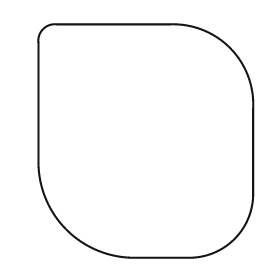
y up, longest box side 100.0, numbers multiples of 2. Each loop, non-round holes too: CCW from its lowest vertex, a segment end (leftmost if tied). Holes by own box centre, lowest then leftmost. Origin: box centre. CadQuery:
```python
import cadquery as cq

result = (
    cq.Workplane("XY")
    .moveTo(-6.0, -50.0)
    .lineTo(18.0, -50.0)
    .threePointArc((38.0, -42.0), (46.0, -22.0))
    .lineTo(46.0, 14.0)
    .threePointArc((36.0, 40.0), (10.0, 50.0))
    .lineTo(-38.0, 50.0)
    .threePointArc((-44.0, 48.0), (-46.0, 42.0))
    .lineTo(-46.0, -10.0)
    .threePointArc((-34.0, -38.0), (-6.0, -50.0))
    .close()
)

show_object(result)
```